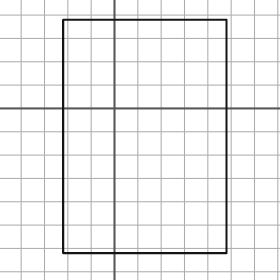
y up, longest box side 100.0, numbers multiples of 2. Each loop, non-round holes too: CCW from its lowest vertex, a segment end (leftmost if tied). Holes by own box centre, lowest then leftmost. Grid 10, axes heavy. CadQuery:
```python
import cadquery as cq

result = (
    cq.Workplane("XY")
    .moveTo(-22.0, -62.0)
    .lineTo(48.0, -62.0)
    .lineTo(48.0, 38.0)
    .lineTo(-22.0, 38.0)
    .close()
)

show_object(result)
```